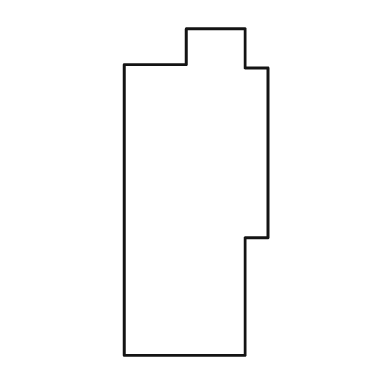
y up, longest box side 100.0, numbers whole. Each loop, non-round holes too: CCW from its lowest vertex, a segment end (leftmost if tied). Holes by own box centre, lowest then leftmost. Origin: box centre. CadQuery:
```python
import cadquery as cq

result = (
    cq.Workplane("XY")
    .moveTo(-22.0, -50.0)
    .lineTo(15.0, -50.0)
    .lineTo(15.0, -14.0)
    .lineTo(22.0, -14.0)
    .lineTo(22.0, 38.0)
    .lineTo(15.0, 38.0)
    .lineTo(15.0, 50.0)
    .lineTo(-3.0, 50.0)
    .lineTo(-3.0, 39.0)
    .lineTo(-22.0, 39.0)
    .close()
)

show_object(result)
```